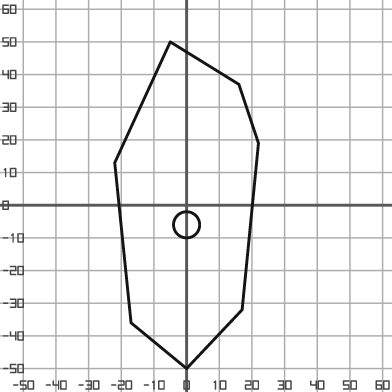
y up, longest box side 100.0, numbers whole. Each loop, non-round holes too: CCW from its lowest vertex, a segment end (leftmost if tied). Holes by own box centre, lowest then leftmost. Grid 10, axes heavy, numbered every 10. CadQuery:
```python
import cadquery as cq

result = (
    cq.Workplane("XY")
    .moveTo(0.0, -50.0)
    .lineTo(17.0, -32.0)
    .lineTo(22.0, 19.0)
    .lineTo(16.0, 37.0)
    .lineTo(-5.0, 50.0)
    .lineTo(-22.0, 13.0)
    .lineTo(-17.0, -36.0)
    .close()
    .moveTo(0.0, -6.0)
    .circle(4.0)
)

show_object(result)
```